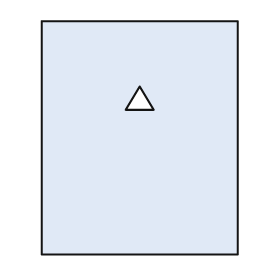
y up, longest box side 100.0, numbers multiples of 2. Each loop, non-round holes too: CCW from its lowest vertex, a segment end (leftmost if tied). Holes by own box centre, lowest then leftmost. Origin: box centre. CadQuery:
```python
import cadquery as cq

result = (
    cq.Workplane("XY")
    .moveTo(-42.0, -50.0)
    .lineTo(42.0, -50.0)
    .lineTo(42.0, 50.0)
    .lineTo(-42.0, 50.0)
    .close()
    .moveTo(-6.0, 12.0)
    .lineTo(6.0, 12.0)
    .lineTo(0.0, 22.0)
    .close()
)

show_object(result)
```